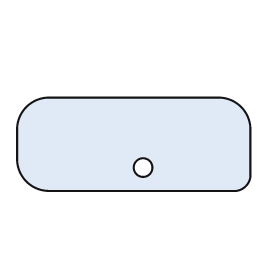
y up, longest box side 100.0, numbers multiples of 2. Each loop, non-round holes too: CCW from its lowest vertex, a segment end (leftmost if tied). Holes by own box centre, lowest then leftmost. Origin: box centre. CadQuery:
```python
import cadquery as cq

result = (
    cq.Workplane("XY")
    .moveTo(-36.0, -20.0)
    .lineTo(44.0, -20.0)
    .threePointArc((48.0, -18.0), (50.0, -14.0))
    .lineTo(50.0, 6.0)
    .threePointArc((46.0, 16.0), (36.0, 20.0))
    .lineTo(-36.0, 20.0)
    .threePointArc((-46.0, 16.0), (-50.0, 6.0))
    .lineTo(-50.0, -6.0)
    .threePointArc((-46.0, -16.0), (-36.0, -20.0))
    .close()
    .moveTo(4.0, -10.0)
    .circle(4.0)
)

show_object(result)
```